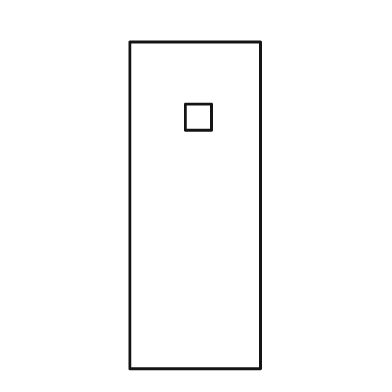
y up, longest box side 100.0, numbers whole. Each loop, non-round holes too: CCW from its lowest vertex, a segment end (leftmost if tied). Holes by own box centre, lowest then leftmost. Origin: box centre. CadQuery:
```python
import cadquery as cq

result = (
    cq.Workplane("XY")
    .moveTo(-20.0, -50.0)
    .lineTo(20.0, -50.0)
    .lineTo(20.0, 50.0)
    .lineTo(-20.0, 50.0)
    .close()
    .moveTo(-3.0, 23.0)
    .lineTo(5.0, 23.0)
    .lineTo(5.0, 31.0)
    .lineTo(-3.0, 31.0)
    .close()
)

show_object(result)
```